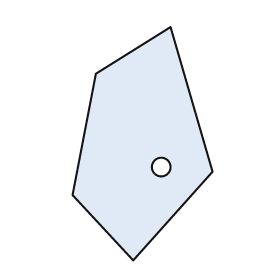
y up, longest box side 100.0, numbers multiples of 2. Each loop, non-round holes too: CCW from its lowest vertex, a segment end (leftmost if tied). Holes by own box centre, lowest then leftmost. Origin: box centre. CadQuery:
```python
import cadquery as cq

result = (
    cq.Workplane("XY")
    .moveTo(-4.0, -50.0)
    .lineTo(30.0, -12.0)
    .lineTo(12.0, 50.0)
    .lineTo(-20.0, 30.0)
    .lineTo(-30.0, -22.0)
    .close()
    .moveTo(8.0, -10.0)
    .circle(4.0)
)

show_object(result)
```